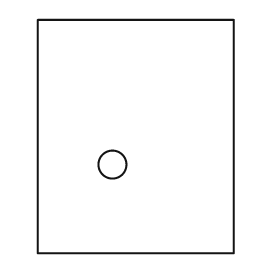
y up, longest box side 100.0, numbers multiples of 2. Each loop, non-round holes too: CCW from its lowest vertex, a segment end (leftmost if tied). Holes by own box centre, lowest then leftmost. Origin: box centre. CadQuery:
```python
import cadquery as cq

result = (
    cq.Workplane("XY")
    .moveTo(-42.0, -50.0)
    .lineTo(42.0, -50.0)
    .lineTo(42.0, 50.0)
    .lineTo(-42.0, 50.0)
    .close()
    .moveTo(-10.0, -12.0)
    .circle(6.0)
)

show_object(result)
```